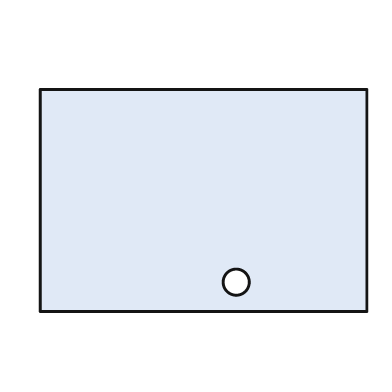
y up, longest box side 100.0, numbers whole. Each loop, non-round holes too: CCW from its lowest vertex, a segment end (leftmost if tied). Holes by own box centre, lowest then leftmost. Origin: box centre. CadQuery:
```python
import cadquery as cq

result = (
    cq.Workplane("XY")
    .moveTo(-50.0, -34.0)
    .lineTo(50.0, -34.0)
    .lineTo(50.0, 34.0)
    .lineTo(-50.0, 34.0)
    .close()
    .moveTo(10.0, -25.0)
    .circle(4.0)
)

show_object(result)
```